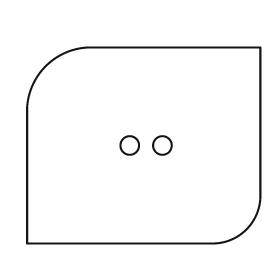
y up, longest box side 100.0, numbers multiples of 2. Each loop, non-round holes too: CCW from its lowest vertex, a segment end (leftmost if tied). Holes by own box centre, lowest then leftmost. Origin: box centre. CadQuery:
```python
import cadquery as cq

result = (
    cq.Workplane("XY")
    .moveTo(-50.0, -42.0)
    .lineTo(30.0, -42.0)
    .threePointArc((44.0, -36.0), (50.0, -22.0))
    .lineTo(50.0, 42.0)
    .lineTo(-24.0, 42.0)
    .threePointArc((-42.0, 34.0), (-50.0, 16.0))
    .close()
    .moveTo(-6.0, 0.0)
    .circle(4.0)
    .moveTo(8.0, 0.0)
    .circle(4.0)
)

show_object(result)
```